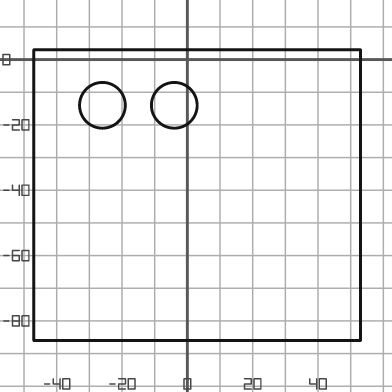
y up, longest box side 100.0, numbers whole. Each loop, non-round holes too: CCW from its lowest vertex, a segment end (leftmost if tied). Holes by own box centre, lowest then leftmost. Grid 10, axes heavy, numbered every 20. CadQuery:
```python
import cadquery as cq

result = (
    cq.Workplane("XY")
    .moveTo(-47.0, -86.0)
    .lineTo(53.0, -86.0)
    .lineTo(53.0, 3.0)
    .lineTo(-47.0, 3.0)
    .close()
    .moveTo(-26.0, -14.0)
    .circle(7.0)
    .moveTo(-4.0, -14.0)
    .circle(7.0)
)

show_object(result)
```